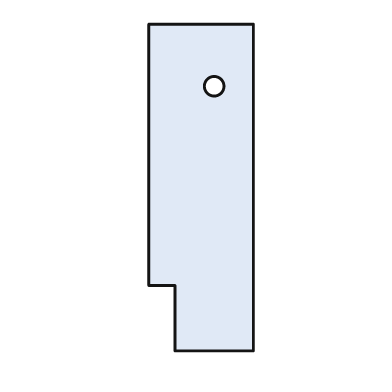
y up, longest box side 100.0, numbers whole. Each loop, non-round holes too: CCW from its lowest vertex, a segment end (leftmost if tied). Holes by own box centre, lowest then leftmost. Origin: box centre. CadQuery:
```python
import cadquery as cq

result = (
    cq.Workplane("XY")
    .moveTo(-8.0, -50.0)
    .lineTo(16.0, -50.0)
    .lineTo(16.0, 50.0)
    .lineTo(-16.0, 50.0)
    .lineTo(-16.0, -30.0)
    .lineTo(-8.0, -30.0)
    .close()
    .moveTo(4.0, 31.0)
    .circle(3.0)
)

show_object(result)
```